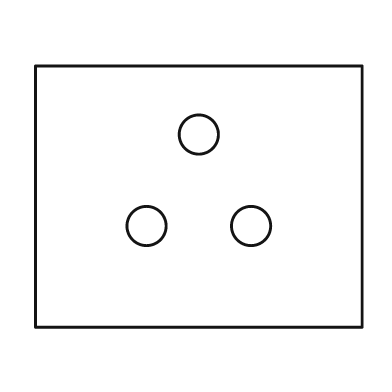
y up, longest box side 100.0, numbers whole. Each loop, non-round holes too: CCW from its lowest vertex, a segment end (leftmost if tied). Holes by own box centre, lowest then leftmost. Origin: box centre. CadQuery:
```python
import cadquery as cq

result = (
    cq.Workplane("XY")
    .moveTo(-50.0, -40.0)
    .lineTo(50.0, -40.0)
    .lineTo(50.0, 40.0)
    .lineTo(-50.0, 40.0)
    .close()
    .moveTo(-16.0, -9.0)
    .circle(6.0)
    .moveTo(16.0, -9.0)
    .circle(6.0)
    .moveTo(0.0, 19.0)
    .circle(6.0)
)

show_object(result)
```